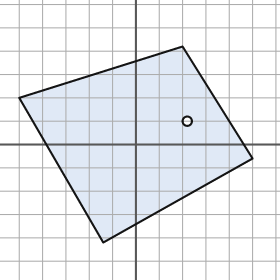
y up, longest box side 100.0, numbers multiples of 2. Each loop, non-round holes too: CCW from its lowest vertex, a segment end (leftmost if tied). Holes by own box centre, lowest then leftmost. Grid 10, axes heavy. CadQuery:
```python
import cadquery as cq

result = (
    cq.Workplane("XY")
    .moveTo(-14.0, -42.0)
    .lineTo(50.0, -6.0)
    .lineTo(20.0, 42.0)
    .lineTo(-50.0, 20.0)
    .close()
    .moveTo(22.0, 10.0)
    .circle(2.0)
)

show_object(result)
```